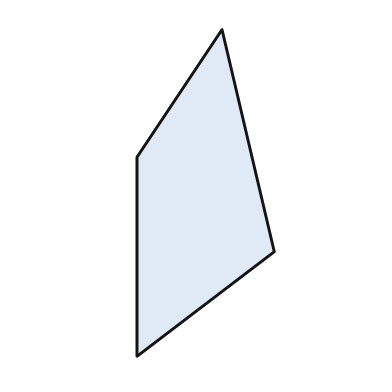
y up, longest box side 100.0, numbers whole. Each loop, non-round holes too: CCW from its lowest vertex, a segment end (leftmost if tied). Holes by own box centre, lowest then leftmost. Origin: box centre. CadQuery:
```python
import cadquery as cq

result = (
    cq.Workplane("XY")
    .moveTo(-21.0, -50.0)
    .lineTo(21.0, -18.0)
    .lineTo(5.0, 50.0)
    .lineTo(-21.0, 11.0)
    .close()
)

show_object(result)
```